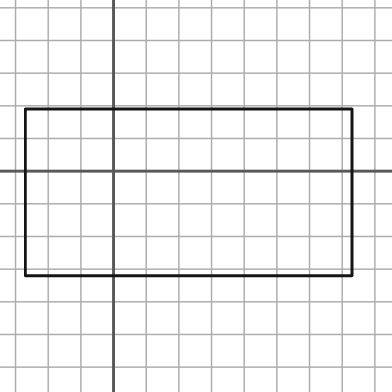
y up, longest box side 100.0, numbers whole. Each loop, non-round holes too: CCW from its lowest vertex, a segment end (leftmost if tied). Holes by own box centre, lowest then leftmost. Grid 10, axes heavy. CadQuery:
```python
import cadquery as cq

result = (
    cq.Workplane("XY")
    .moveTo(-27.0, -32.0)
    .lineTo(73.0, -32.0)
    .lineTo(73.0, 19.0)
    .lineTo(-27.0, 19.0)
    .close()
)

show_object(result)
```